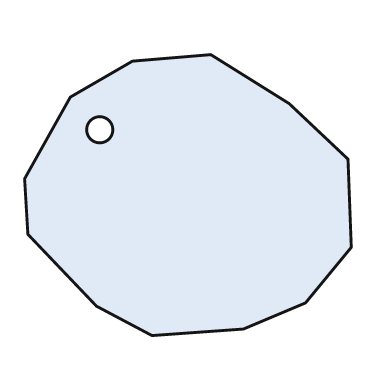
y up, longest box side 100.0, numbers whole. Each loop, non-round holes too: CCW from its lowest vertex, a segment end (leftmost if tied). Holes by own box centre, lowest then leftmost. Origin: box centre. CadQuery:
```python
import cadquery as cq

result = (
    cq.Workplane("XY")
    .moveTo(-11.0, -43.0)
    .lineTo(17.0, -41.0)
    .lineTo(36.0, -33.0)
    .lineTo(50.0, -16.0)
    .lineTo(49.0, 11.0)
    .lineTo(31.0, 28.0)
    .lineTo(7.0, 43.0)
    .lineTo(-17.0, 41.0)
    .lineTo(-36.0, 30.0)
    .lineTo(-50.0, 5.0)
    .lineTo(-49.0, -12.0)
    .lineTo(-28.0, -34.0)
    .close()
    .moveTo(-27.0, 20.0)
    .circle(4.0)
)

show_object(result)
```